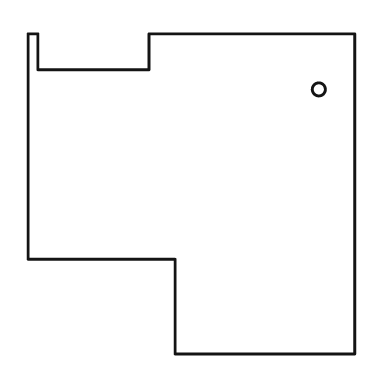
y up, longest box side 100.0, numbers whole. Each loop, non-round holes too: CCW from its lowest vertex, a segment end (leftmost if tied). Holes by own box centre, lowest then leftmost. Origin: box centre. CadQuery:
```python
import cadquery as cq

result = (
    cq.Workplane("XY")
    .moveTo(-5.0, -49.0)
    .lineTo(50.0, -49.0)
    .lineTo(50.0, 49.0)
    .lineTo(-13.0, 49.0)
    .lineTo(-13.0, 38.0)
    .lineTo(-47.0, 38.0)
    .lineTo(-47.0, 49.0)
    .lineTo(-50.0, 49.0)
    .lineTo(-50.0, -20.0)
    .lineTo(-5.0, -20.0)
    .close()
    .moveTo(39.0, 32.0)
    .circle(2.0)
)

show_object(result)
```